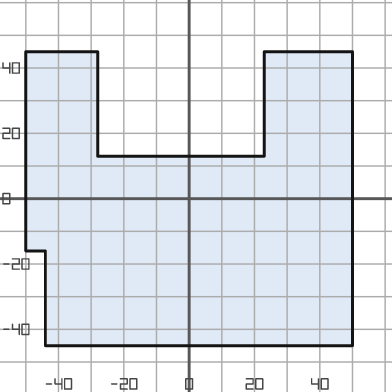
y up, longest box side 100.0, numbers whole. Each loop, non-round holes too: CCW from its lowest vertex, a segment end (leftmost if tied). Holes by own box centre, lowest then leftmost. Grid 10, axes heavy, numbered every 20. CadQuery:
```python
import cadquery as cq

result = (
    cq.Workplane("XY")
    .moveTo(-44.0, -45.0)
    .lineTo(50.0, -45.0)
    .lineTo(50.0, 45.0)
    .lineTo(23.0, 45.0)
    .lineTo(23.0, 13.0)
    .lineTo(-28.0, 13.0)
    .lineTo(-28.0, 45.0)
    .lineTo(-50.0, 45.0)
    .lineTo(-50.0, -16.0)
    .lineTo(-44.0, -16.0)
    .close()
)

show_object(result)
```